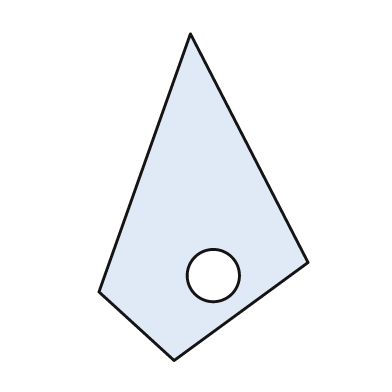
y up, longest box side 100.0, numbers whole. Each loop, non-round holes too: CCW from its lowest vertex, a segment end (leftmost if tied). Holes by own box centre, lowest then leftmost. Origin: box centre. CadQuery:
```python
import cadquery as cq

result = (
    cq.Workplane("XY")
    .moveTo(-9.0, -50.0)
    .lineTo(32.0, -20.0)
    .lineTo(-4.0, 50.0)
    .lineTo(-32.0, -29.0)
    .close()
    .moveTo(3.0, -24.0)
    .circle(8.0)
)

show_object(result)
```